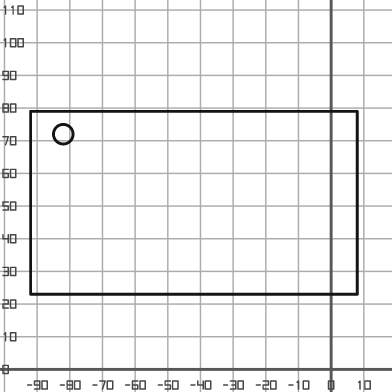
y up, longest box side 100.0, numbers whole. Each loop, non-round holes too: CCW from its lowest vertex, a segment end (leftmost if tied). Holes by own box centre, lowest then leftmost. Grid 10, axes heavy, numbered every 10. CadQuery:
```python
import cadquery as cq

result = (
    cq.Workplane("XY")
    .moveTo(-92.0, 23.0)
    .lineTo(8.0, 23.0)
    .lineTo(8.0, 79.0)
    .lineTo(-92.0, 79.0)
    .close()
    .moveTo(-82.0, 72.0)
    .circle(3.0)
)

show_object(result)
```